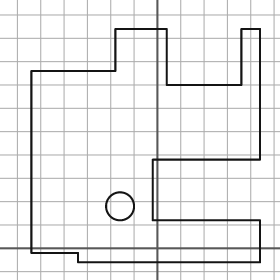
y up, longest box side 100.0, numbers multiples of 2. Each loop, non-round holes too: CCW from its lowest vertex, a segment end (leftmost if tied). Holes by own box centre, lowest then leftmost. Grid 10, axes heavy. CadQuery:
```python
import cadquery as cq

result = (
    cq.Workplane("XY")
    .moveTo(-34.0, -6.0)
    .lineTo(44.0, -6.0)
    .lineTo(44.0, 12.0)
    .lineTo(-2.0, 12.0)
    .lineTo(-2.0, 38.0)
    .lineTo(44.0, 38.0)
    .lineTo(44.0, 94.0)
    .lineTo(36.0, 94.0)
    .lineTo(36.0, 70.0)
    .lineTo(4.0, 70.0)
    .lineTo(4.0, 94.0)
    .lineTo(-18.0, 94.0)
    .lineTo(-18.0, 76.0)
    .lineTo(-54.0, 76.0)
    .lineTo(-54.0, -2.0)
    .lineTo(-34.0, -2.0)
    .close()
    .moveTo(-16.0, 18.0)
    .circle(6.0)
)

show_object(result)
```